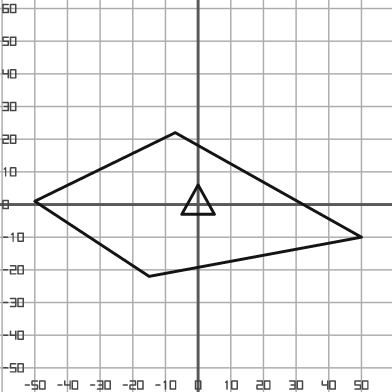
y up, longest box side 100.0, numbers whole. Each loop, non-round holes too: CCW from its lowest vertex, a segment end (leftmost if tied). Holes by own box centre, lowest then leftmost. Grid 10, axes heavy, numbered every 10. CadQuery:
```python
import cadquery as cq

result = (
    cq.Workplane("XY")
    .moveTo(-15.0, -22.0)
    .lineTo(50.0, -10.0)
    .lineTo(-7.0, 22.0)
    .lineTo(-50.0, 1.0)
    .close()
    .moveTo(-5.0, -3.0)
    .lineTo(5.0, -3.0)
    .lineTo(0.0, 6.0)
    .close()
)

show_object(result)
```